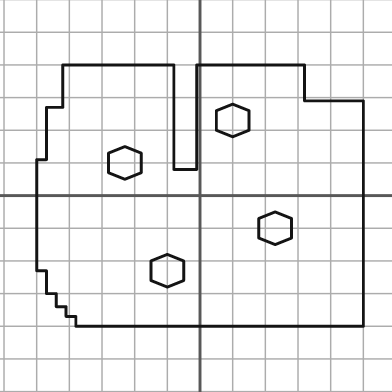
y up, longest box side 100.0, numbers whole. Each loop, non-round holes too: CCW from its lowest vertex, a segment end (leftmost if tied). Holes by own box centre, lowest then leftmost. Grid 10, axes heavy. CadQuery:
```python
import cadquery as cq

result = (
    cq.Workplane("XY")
    .moveTo(-38.0, -40.0)
    .lineTo(50.0, -40.0)
    .lineTo(50.0, 29.0)
    .lineTo(32.0, 29.0)
    .lineTo(32.0, 40.0)
    .lineTo(-1.0, 40.0)
    .lineTo(-1.0, 8.0)
    .lineTo(-8.0, 8.0)
    .lineTo(-8.0, 40.0)
    .lineTo(-42.0, 40.0)
    .lineTo(-42.0, 27.0)
    .lineTo(-47.0, 27.0)
    .lineTo(-47.0, 11.0)
    .lineTo(-50.0, 11.0)
    .lineTo(-50.0, -23.0)
    .lineTo(-47.0, -23.0)
    .lineTo(-47.0, -30.0)
    .lineTo(-44.0, -30.0)
    .lineTo(-44.0, -34.0)
    .lineTo(-41.0, -34.0)
    .lineTo(-41.0, -37.0)
    .lineTo(-38.0, -37.0)
    .close()
    .moveTo(-10.0, -28.0)
    .lineTo(-5.0, -26.0)
    .lineTo(-5.0, -20.0)
    .lineTo(-10.0, -18.0)
    .lineTo(-15.0, -20.0)
    .lineTo(-15.0, -26.0)
    .close()
    .moveTo(23.0, -15.0)
    .lineTo(28.0, -13.0)
    .lineTo(28.0, -7.0)
    .lineTo(23.0, -5.0)
    .lineTo(18.0, -7.0)
    .lineTo(18.0, -13.0)
    .close()
    .moveTo(-23.0, 5.0)
    .lineTo(-18.0, 7.0)
    .lineTo(-18.0, 13.0)
    .lineTo(-23.0, 15.0)
    .lineTo(-28.0, 13.0)
    .lineTo(-28.0, 7.0)
    .close()
    .moveTo(10.0, 18.0)
    .lineTo(15.0, 20.0)
    .lineTo(15.0, 26.0)
    .lineTo(10.0, 28.0)
    .lineTo(5.0, 26.0)
    .lineTo(5.0, 20.0)
    .close()
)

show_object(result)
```